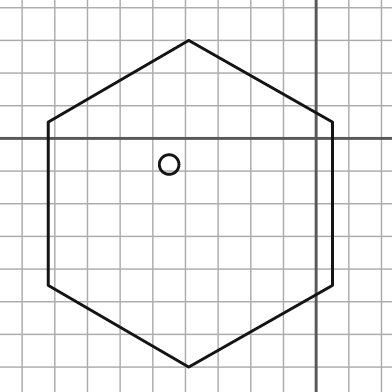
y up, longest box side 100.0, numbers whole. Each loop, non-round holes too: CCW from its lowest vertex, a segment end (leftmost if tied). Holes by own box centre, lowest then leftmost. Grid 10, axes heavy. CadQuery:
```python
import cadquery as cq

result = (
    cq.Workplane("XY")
    .moveTo(-39.0, -70.0)
    .lineTo(5.0, -45.0)
    .lineTo(5.0, 5.0)
    .lineTo(-39.0, 30.0)
    .lineTo(-82.0, 5.0)
    .lineTo(-82.0, -45.0)
    .close()
    .moveTo(-45.0, -8.0)
    .circle(3.0)
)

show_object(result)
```